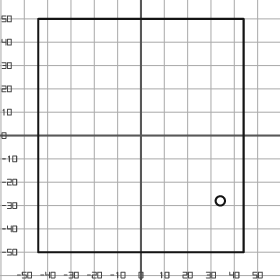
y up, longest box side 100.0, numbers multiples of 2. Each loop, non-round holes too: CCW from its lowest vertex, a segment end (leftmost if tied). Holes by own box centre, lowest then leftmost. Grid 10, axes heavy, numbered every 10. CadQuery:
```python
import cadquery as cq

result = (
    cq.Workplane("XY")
    .moveTo(-44.0, -50.0)
    .lineTo(44.0, -50.0)
    .lineTo(44.0, 50.0)
    .lineTo(-44.0, 50.0)
    .close()
    .moveTo(34.0, -28.0)
    .circle(2.0)
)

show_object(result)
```